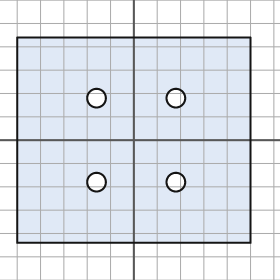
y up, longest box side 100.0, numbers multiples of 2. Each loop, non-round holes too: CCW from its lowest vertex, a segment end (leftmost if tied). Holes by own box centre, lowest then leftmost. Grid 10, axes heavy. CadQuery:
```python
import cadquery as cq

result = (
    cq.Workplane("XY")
    .moveTo(-50.0, -44.0)
    .lineTo(50.0, -44.0)
    .lineTo(50.0, 44.0)
    .lineTo(-50.0, 44.0)
    .close()
    .moveTo(-16.0, -18.0)
    .circle(4.0)
    .moveTo(18.0, -18.0)
    .circle(4.0)
    .moveTo(-16.0, 18.0)
    .circle(4.0)
    .moveTo(18.0, 18.0)
    .circle(4.0)
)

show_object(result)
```